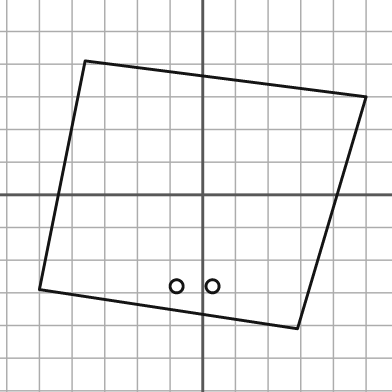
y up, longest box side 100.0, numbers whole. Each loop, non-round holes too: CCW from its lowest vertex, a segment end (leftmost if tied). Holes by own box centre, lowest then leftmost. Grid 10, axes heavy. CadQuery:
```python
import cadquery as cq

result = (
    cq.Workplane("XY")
    .moveTo(29.0, -41.0)
    .lineTo(50.0, 30.0)
    .lineTo(-36.0, 41.0)
    .lineTo(-50.0, -29.0)
    .close()
    .moveTo(-8.0, -28.0)
    .circle(2.0)
    .moveTo(3.0, -28.0)
    .circle(2.0)
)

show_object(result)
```